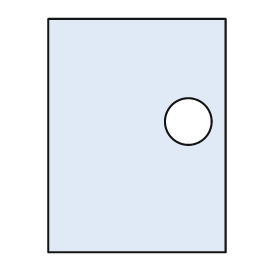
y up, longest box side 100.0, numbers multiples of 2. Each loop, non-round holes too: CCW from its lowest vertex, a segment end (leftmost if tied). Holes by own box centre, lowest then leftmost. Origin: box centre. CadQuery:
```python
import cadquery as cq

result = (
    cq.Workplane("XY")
    .moveTo(-38.0, -50.0)
    .lineTo(38.0, -50.0)
    .lineTo(38.0, 50.0)
    .lineTo(-38.0, 50.0)
    .close()
    .moveTo(22.0, 6.0)
    .circle(10.0)
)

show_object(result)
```